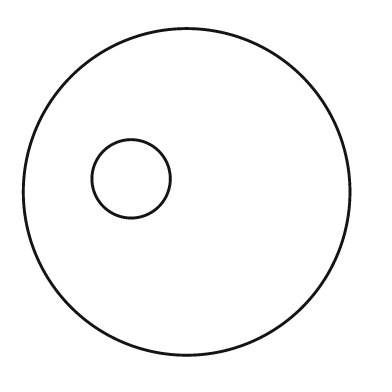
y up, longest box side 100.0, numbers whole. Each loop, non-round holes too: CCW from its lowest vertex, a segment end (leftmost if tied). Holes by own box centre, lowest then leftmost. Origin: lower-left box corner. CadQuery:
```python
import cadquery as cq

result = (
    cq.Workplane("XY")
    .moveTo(50.0, 50.0)
    .circle(50.0)
    .moveTo(33.0, 54.0)
    .circle(12.0)
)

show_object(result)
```